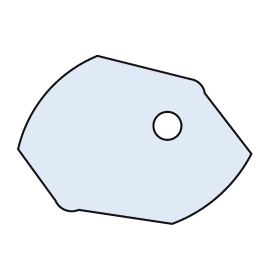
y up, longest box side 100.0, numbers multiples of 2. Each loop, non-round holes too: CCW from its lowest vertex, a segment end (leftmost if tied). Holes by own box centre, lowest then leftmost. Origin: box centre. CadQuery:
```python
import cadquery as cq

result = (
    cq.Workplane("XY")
    .moveTo(16.0, -36.0)
    .threePointArc((36.0, -24.0), (50.0, -6.0))
    .lineTo(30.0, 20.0)
    .threePointArc((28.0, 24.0), (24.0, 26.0))
    .lineTo(-16.0, 36.0)
    .threePointArc((-38.0, 20.0), (-50.0, -4.0))
    .lineTo(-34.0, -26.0)
    .threePointArc((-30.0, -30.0), (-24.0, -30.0))
    .close()
    .moveTo(14.0, 6.0)
    .circle(6.0)
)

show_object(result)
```